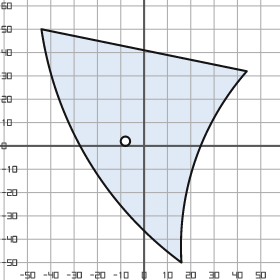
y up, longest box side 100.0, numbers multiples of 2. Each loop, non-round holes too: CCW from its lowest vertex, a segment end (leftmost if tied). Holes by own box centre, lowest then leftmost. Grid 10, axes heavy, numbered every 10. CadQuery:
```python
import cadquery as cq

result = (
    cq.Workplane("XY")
    .moveTo(16.0, -50.0)
    .threePointArc((22.0, -6.0), (44.0, 32.0))
    .lineTo(-44.0, 50.0)
    .threePointArc((-24.0, -6.0), (16.0, -50.0))
    .close()
    .moveTo(-8.0, 2.0)
    .circle(2.0)
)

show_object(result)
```